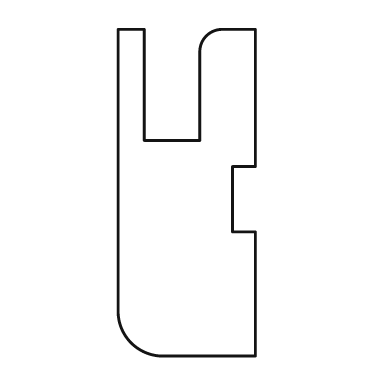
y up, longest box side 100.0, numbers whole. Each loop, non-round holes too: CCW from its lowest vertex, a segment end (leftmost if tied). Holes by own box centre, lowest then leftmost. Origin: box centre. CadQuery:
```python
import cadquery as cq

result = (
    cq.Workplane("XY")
    .moveTo(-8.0, -50.0)
    .lineTo(21.0, -50.0)
    .lineTo(21.0, -12.0)
    .lineTo(14.0, -12.0)
    .lineTo(14.0, 8.0)
    .lineTo(21.0, 8.0)
    .lineTo(21.0, 50.0)
    .lineTo(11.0, 50.0)
    .threePointArc((6.0, 48.0), (4.0, 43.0))
    .lineTo(4.0, 16.0)
    .lineTo(-13.0, 16.0)
    .lineTo(-13.0, 50.0)
    .lineTo(-21.0, 50.0)
    .lineTo(-21.0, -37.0)
    .threePointArc((-17.0, -46.0), (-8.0, -50.0))
    .close()
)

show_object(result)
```